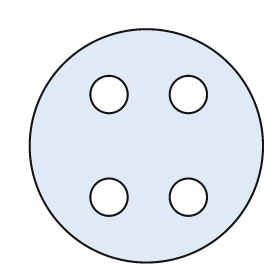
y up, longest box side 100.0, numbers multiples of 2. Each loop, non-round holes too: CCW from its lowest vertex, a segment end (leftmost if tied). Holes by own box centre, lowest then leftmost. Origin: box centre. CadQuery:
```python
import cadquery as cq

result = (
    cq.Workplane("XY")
    .moveTo(0.0, 0.0)
    .circle(50.0)
    .moveTo(-16.0, -22.0)
    .circle(8.0)
    .moveTo(18.0, -22.0)
    .circle(8.0)
    .moveTo(-16.0, 22.0)
    .circle(8.0)
    .moveTo(18.0, 22.0)
    .circle(8.0)
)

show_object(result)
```